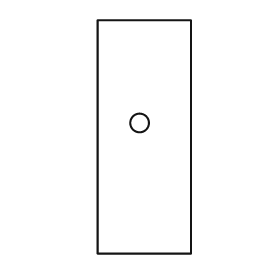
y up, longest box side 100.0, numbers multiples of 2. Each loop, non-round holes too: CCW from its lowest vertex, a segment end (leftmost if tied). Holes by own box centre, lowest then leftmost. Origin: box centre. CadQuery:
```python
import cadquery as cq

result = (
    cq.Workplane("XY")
    .moveTo(-20.0, -50.0)
    .lineTo(20.0, -50.0)
    .lineTo(20.0, 50.0)
    .lineTo(-20.0, 50.0)
    .close()
    .moveTo(-2.0, 6.0)
    .circle(4.0)
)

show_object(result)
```